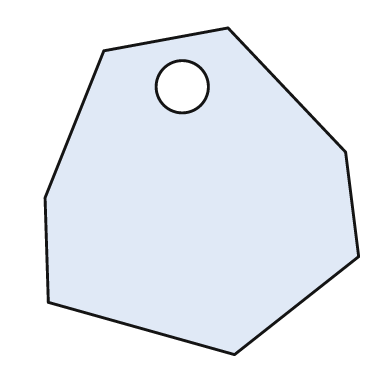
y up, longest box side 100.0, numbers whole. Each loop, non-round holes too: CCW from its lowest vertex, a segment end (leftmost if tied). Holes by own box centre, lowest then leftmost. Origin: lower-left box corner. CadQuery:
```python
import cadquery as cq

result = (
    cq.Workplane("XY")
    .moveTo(58.0, 0.0)
    .lineTo(96.0, 30.0)
    .lineTo(92.0, 62.0)
    .lineTo(56.0, 100.0)
    .lineTo(18.0, 93.0)
    .lineTo(0.0, 48.0)
    .lineTo(1.0, 16.0)
    .close()
    .moveTo(42.0, 82.0)
    .circle(8.0)
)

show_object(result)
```